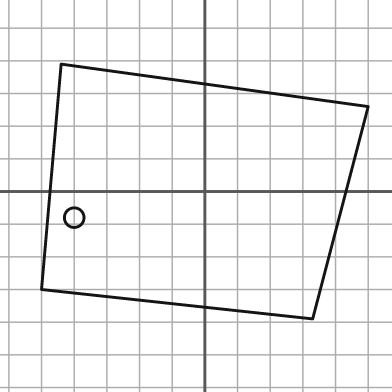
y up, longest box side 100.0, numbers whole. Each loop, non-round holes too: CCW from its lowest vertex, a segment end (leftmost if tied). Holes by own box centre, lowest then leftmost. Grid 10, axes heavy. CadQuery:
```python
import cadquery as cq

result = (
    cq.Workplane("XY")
    .moveTo(33.0, -39.0)
    .lineTo(50.0, 26.0)
    .lineTo(-44.0, 39.0)
    .lineTo(-50.0, -30.0)
    .close()
    .moveTo(-40.0, -8.0)
    .circle(3.0)
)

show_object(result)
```